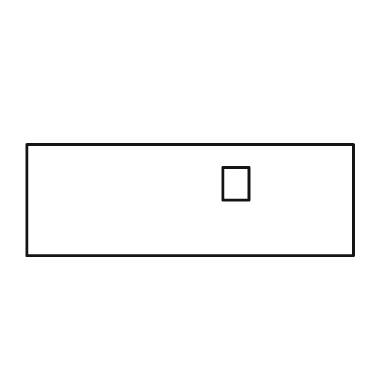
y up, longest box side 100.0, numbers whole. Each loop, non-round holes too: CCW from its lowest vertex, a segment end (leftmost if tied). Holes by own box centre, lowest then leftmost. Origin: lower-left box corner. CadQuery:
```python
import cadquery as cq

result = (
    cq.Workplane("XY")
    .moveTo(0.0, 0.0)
    .lineTo(100.0, 0.0)
    .lineTo(100.0, 34.0)
    .lineTo(0.0, 34.0)
    .close()
    .moveTo(60.0, 17.0)
    .lineTo(68.0, 17.0)
    .lineTo(68.0, 27.0)
    .lineTo(60.0, 27.0)
    .close()
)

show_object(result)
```